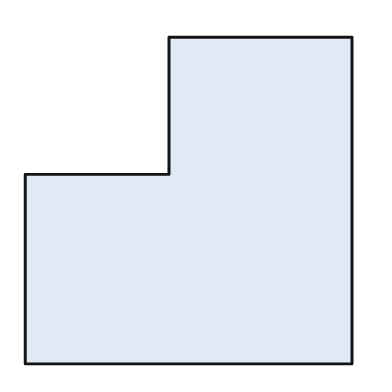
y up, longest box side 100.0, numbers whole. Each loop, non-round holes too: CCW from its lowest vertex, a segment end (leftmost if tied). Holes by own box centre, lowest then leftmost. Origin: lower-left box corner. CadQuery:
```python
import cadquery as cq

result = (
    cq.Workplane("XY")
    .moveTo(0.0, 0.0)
    .lineTo(100.0, 0.0)
    .lineTo(100.0, 100.0)
    .lineTo(44.0, 100.0)
    .lineTo(44.0, 58.0)
    .lineTo(0.0, 58.0)
    .close()
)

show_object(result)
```